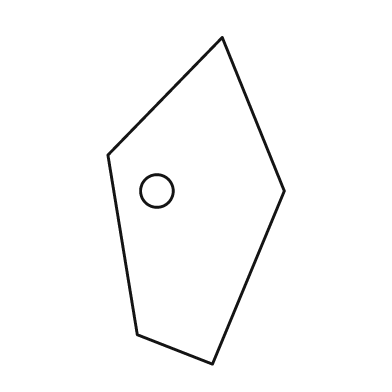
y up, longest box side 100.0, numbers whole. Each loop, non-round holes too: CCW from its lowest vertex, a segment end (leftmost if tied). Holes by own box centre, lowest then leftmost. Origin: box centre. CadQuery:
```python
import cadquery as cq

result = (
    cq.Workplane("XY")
    .moveTo(5.0, -50.0)
    .lineTo(27.0, 3.0)
    .lineTo(8.0, 50.0)
    .lineTo(-27.0, 14.0)
    .lineTo(-18.0, -41.0)
    .close()
    .moveTo(-12.0, 3.0)
    .circle(5.0)
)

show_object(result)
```